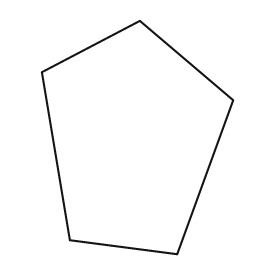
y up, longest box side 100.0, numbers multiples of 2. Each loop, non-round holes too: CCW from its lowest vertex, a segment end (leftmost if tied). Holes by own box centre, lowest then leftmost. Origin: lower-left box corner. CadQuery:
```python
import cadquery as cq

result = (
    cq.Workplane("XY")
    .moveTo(58.0, 0.0)
    .lineTo(82.0, 66.0)
    .lineTo(42.0, 100.0)
    .lineTo(0.0, 78.0)
    .lineTo(12.0, 6.0)
    .close()
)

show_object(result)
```